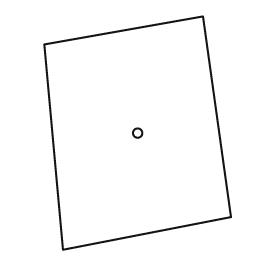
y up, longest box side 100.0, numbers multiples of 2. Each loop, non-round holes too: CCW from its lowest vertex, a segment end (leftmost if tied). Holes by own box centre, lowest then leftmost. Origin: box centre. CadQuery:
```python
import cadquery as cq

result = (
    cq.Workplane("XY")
    .moveTo(-32.0, -50.0)
    .lineTo(40.0, -36.0)
    .lineTo(28.0, 50.0)
    .lineTo(-40.0, 38.0)
    .close()
    .moveTo(0.0, 0.0)
    .circle(2.0)
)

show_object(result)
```